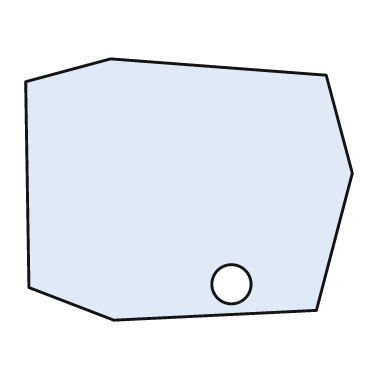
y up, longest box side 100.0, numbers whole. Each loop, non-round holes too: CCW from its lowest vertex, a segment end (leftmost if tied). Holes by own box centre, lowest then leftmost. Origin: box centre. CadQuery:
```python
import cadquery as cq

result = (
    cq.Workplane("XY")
    .moveTo(-23.0, -40.0)
    .lineTo(39.0, -37.0)
    .lineTo(50.0, 5.0)
    .lineTo(42.0, 35.0)
    .lineTo(-24.0, 40.0)
    .lineTo(-50.0, 33.0)
    .lineTo(-49.0, -30.0)
    .close()
    .moveTo(13.0, -29.0)
    .circle(6.0)
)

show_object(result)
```